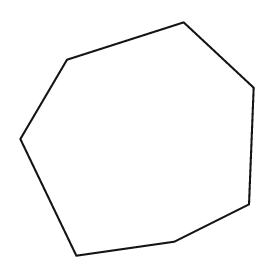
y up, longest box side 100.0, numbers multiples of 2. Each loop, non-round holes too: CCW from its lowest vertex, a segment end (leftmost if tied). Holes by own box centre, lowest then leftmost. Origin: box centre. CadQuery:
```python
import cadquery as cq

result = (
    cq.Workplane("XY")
    .moveTo(-26.0, -50.0)
    .lineTo(16.0, -44.0)
    .lineTo(48.0, -28.0)
    .lineTo(50.0, 22.0)
    .lineTo(20.0, 50.0)
    .lineTo(-30.0, 34.0)
    .lineTo(-50.0, 0.0)
    .close()
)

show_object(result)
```